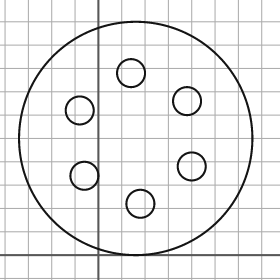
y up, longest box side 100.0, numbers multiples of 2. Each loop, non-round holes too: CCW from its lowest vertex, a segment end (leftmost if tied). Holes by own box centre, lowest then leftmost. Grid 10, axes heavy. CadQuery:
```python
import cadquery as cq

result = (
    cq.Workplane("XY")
    .moveTo(16.0, 50.0)
    .circle(50.0)
    .moveTo(18.0, 22.0)
    .circle(6.0)
    .moveTo(-6.0, 34.0)
    .circle(6.0)
    .moveTo(40.0, 38.0)
    .circle(6.0)
    .moveTo(-8.0, 62.0)
    .circle(6.0)
    .moveTo(38.0, 66.0)
    .circle(6.0)
    .moveTo(14.0, 78.0)
    .circle(6.0)
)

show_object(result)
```